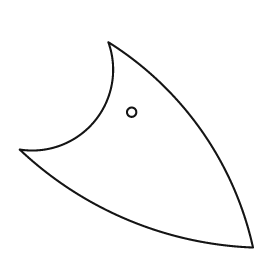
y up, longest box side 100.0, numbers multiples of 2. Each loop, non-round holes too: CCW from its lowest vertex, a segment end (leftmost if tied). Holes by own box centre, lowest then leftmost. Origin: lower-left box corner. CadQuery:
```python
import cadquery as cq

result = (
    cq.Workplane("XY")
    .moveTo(100.0, 0.0)
    .threePointArc((78.0, 50.0), (38.0, 88.0))
    .threePointArc((32.0, 54.0), (0.0, 42.0))
    .threePointArc((46.0, 12.0), (100.0, 0.0))
    .close()
    .moveTo(48.0, 58.0)
    .circle(2.0)
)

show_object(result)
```